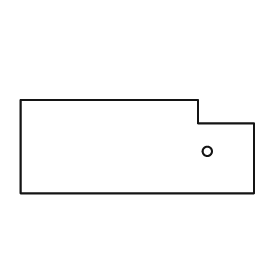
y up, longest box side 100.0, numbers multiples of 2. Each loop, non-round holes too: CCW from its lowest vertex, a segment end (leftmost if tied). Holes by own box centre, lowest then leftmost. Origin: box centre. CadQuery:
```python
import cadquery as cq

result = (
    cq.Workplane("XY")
    .moveTo(-50.0, -20.0)
    .lineTo(50.0, -20.0)
    .lineTo(50.0, 10.0)
    .lineTo(26.0, 10.0)
    .lineTo(26.0, 20.0)
    .lineTo(-50.0, 20.0)
    .close()
    .moveTo(30.0, -2.0)
    .circle(2.0)
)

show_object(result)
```